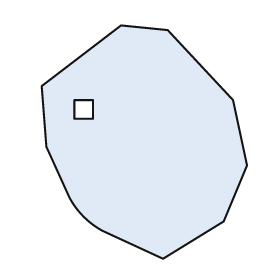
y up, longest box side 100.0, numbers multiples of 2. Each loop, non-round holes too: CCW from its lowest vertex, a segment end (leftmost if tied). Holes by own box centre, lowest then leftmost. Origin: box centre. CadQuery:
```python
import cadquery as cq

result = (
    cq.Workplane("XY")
    .moveTo(8.0, -50.0)
    .lineTo(34.0, -34.0)
    .lineTo(44.0, -10.0)
    .lineTo(38.0, 18.0)
    .lineTo(10.0, 48.0)
    .lineTo(-10.0, 50.0)
    .lineTo(-44.0, 24.0)
    .lineTo(-42.0, -2.0)
    .lineTo(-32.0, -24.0)
    .threePointArc((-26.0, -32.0), (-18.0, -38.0))
    .close()
    .moveTo(-30.0, 10.0)
    .lineTo(-22.0, 10.0)
    .lineTo(-22.0, 18.0)
    .lineTo(-30.0, 18.0)
    .close()
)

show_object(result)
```